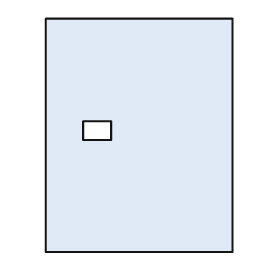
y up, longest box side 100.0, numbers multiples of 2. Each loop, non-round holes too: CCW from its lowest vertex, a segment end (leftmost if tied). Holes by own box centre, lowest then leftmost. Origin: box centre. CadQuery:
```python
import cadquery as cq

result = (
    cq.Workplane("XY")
    .moveTo(-40.0, -50.0)
    .lineTo(40.0, -50.0)
    .lineTo(40.0, 50.0)
    .lineTo(-40.0, 50.0)
    .close()
    .moveTo(-24.0, -2.0)
    .lineTo(-12.0, -2.0)
    .lineTo(-12.0, 6.0)
    .lineTo(-24.0, 6.0)
    .close()
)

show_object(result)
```